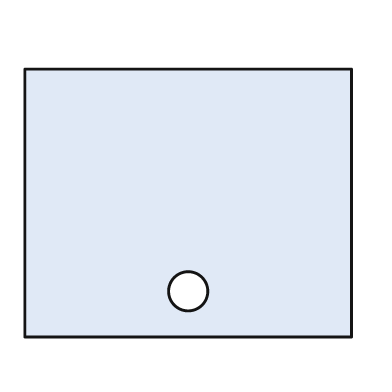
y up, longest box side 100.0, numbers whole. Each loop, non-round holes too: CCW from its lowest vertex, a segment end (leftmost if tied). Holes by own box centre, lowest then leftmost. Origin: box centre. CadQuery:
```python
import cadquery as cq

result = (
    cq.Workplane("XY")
    .moveTo(-50.0, -41.0)
    .lineTo(50.0, -41.0)
    .lineTo(50.0, 41.0)
    .lineTo(-50.0, 41.0)
    .close()
    .moveTo(0.0, -27.0)
    .circle(6.0)
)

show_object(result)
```